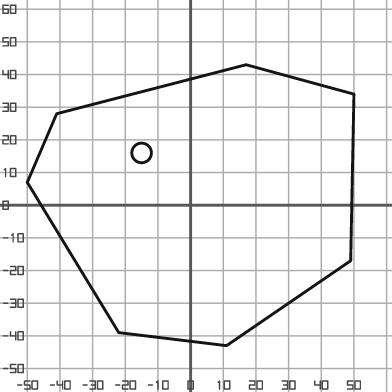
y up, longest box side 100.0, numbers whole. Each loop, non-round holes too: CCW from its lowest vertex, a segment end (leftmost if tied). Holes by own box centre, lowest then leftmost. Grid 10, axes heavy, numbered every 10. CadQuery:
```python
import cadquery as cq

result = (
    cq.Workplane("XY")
    .moveTo(11.0, -43.0)
    .lineTo(49.0, -17.0)
    .lineTo(50.0, 34.0)
    .lineTo(17.0, 43.0)
    .lineTo(-41.0, 28.0)
    .lineTo(-50.0, 7.0)
    .lineTo(-22.0, -39.0)
    .close()
    .moveTo(-15.0, 16.0)
    .circle(3.0)
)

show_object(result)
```